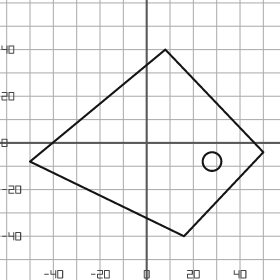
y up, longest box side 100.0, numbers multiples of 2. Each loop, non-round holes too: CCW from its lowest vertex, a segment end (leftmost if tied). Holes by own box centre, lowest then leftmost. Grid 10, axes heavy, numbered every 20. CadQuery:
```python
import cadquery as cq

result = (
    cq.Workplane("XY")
    .moveTo(16.0, -40.0)
    .lineTo(50.0, -4.0)
    .lineTo(8.0, 40.0)
    .lineTo(-50.0, -8.0)
    .close()
    .moveTo(28.0, -8.0)
    .circle(4.0)
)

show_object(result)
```